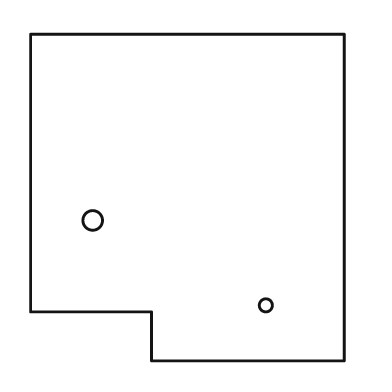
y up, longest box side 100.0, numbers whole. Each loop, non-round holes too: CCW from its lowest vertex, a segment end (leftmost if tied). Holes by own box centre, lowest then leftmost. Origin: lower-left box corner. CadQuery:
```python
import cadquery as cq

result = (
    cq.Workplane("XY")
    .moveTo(37.0, 0.0)
    .lineTo(96.0, 0.0)
    .lineTo(96.0, 100.0)
    .lineTo(0.0, 100.0)
    .lineTo(0.0, 15.0)
    .lineTo(37.0, 15.0)
    .close()
    .moveTo(72.0, 17.0)
    .circle(2.0)
    .moveTo(19.0, 43.0)
    .circle(3.0)
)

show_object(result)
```